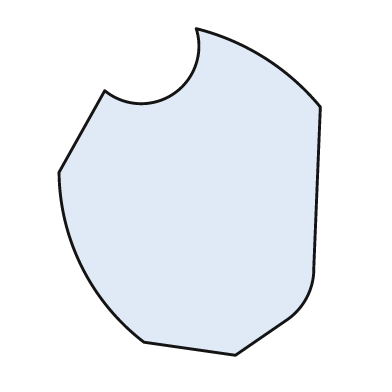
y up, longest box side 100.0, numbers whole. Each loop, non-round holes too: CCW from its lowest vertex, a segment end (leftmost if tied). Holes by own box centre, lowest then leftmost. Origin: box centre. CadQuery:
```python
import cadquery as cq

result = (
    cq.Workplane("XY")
    .moveTo(14.0, -50.0)
    .lineTo(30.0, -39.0)
    .threePointArc((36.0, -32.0), (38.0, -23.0))
    .lineTo(40.0, 26.0)
    .threePointArc((23.0, 41.0), (2.0, 50.0))
    .threePointArc((-5.0, 30.0), (-26.0, 31.0))
    .lineTo(-40.0, 6.0)
    .threePointArc((-33.0, -23.0), (-14.0, -46.0))
    .close()
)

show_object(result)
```